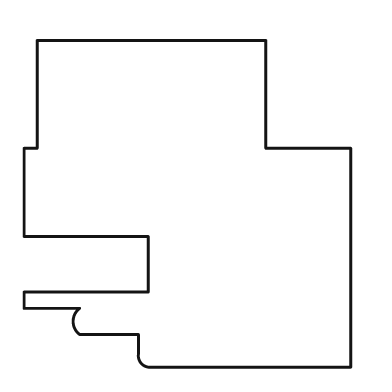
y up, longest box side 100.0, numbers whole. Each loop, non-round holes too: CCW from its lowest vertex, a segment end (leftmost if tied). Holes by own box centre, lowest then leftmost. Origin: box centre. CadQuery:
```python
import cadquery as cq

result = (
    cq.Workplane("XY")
    .moveTo(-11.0, -50.0)
    .lineTo(50.0, -50.0)
    .lineTo(50.0, 17.0)
    .lineTo(24.0, 17.0)
    .lineTo(24.0, 50.0)
    .lineTo(-46.0, 50.0)
    .lineTo(-46.0, 17.0)
    .lineTo(-50.0, 17.0)
    .lineTo(-50.0, -10.0)
    .lineTo(-12.0, -10.0)
    .lineTo(-12.0, -27.0)
    .lineTo(-50.0, -27.0)
    .lineTo(-50.0, -32.0)
    .lineTo(-33.0, -32.0)
    .threePointArc((-35.0, -36.0), (-33.0, -40.0))
    .lineTo(-15.0, -40.0)
    .lineTo(-15.0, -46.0)
    .threePointArc((-14.0, -49.0), (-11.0, -50.0))
    .close()
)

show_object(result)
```